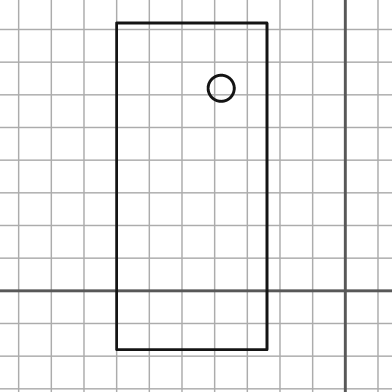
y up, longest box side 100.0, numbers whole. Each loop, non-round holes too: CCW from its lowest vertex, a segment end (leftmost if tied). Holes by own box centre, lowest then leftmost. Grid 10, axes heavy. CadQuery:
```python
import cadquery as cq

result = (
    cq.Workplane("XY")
    .moveTo(-70.0, -18.0)
    .lineTo(-24.0, -18.0)
    .lineTo(-24.0, 82.0)
    .lineTo(-70.0, 82.0)
    .close()
    .moveTo(-38.0, 62.0)
    .circle(4.0)
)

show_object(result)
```